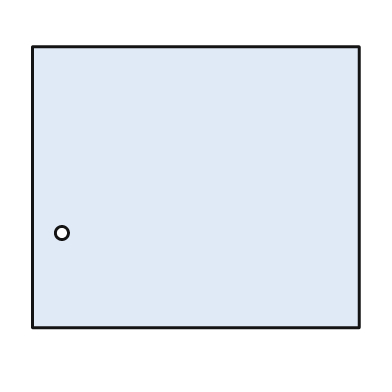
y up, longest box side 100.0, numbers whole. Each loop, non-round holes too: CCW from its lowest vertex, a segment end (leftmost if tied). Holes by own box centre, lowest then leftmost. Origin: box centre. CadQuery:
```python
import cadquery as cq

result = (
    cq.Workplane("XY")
    .moveTo(-50.0, -43.0)
    .lineTo(50.0, -43.0)
    .lineTo(50.0, 43.0)
    .lineTo(-50.0, 43.0)
    .close()
    .moveTo(-41.0, -14.0)
    .circle(2.0)
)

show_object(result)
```